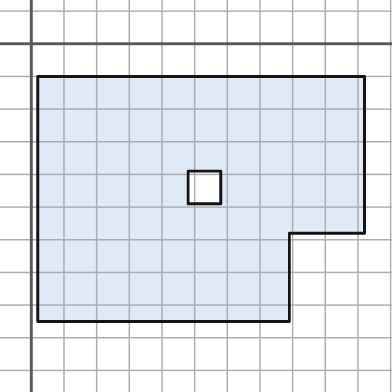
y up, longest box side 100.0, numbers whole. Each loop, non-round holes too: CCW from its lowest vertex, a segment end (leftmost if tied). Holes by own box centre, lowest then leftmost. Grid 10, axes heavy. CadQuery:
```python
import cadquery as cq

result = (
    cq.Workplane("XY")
    .moveTo(2.0, -85.0)
    .lineTo(79.0, -85.0)
    .lineTo(79.0, -58.0)
    .lineTo(102.0, -58.0)
    .lineTo(102.0, -10.0)
    .lineTo(2.0, -10.0)
    .close()
    .moveTo(48.0, -49.0)
    .lineTo(58.0, -49.0)
    .lineTo(58.0, -39.0)
    .lineTo(48.0, -39.0)
    .close()
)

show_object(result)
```